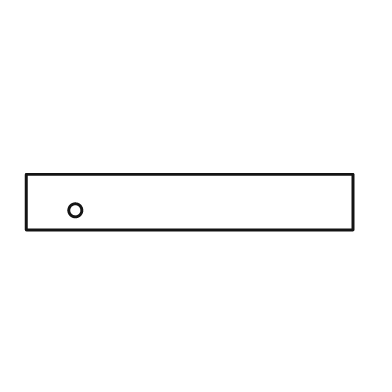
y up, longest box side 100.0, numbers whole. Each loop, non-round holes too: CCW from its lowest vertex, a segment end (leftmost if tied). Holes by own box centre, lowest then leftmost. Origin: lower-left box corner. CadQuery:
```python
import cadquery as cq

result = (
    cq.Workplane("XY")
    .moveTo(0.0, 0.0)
    .lineTo(100.0, 0.0)
    .lineTo(100.0, 17.0)
    .lineTo(0.0, 17.0)
    .close()
    .moveTo(15.0, 6.0)
    .circle(2.0)
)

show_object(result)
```